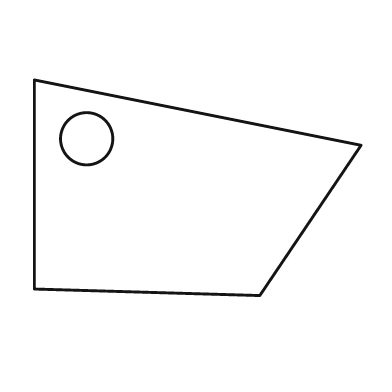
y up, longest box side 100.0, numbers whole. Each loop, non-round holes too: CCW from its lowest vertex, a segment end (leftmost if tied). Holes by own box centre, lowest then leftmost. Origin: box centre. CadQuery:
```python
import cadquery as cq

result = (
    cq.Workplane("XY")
    .moveTo(19.0, -33.0)
    .lineTo(50.0, 13.0)
    .lineTo(-50.0, 33.0)
    .lineTo(-50.0, -31.0)
    .close()
    .moveTo(-34.0, 15.0)
    .circle(8.0)
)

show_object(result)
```